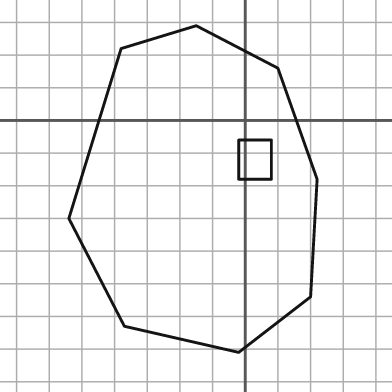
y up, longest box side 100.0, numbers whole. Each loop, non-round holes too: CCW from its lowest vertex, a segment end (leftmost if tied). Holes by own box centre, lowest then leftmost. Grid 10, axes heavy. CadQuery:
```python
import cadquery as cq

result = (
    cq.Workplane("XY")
    .moveTo(-2.0, -71.0)
    .lineTo(20.0, -54.0)
    .lineTo(22.0, -18.0)
    .lineTo(10.0, 16.0)
    .lineTo(-15.0, 29.0)
    .lineTo(-38.0, 22.0)
    .lineTo(-54.0, -30.0)
    .lineTo(-37.0, -63.0)
    .close()
    .moveTo(-2.0, -18.0)
    .lineTo(8.0, -18.0)
    .lineTo(8.0, -6.0)
    .lineTo(-2.0, -6.0)
    .close()
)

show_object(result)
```